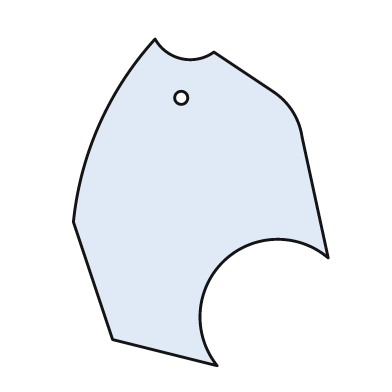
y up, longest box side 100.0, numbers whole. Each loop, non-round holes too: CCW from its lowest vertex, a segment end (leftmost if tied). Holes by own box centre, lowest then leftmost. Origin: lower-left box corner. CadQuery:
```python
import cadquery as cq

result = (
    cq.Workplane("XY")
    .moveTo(44.0, 0.0)
    .threePointArc((46.0, 32.0), (78.0, 33.0))
    .lineTo(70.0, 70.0)
    .threePointArc((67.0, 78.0), (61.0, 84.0))
    .lineTo(43.0, 96.0)
    .threePointArc((33.0, 94.0), (25.0, 100.0))
    .threePointArc((8.0, 74.0), (0.0, 44.0))
    .lineTo(12.0, 8.0)
    .close()
    .moveTo(33.0, 82.0)
    .circle(2.0)
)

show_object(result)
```